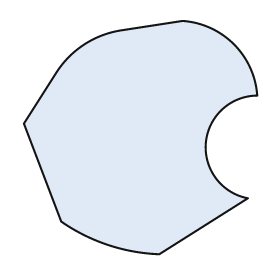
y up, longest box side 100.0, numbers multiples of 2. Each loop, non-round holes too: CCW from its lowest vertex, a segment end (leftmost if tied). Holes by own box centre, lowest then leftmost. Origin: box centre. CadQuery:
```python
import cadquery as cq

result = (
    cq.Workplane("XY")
    .moveTo(8.0, -50.0)
    .lineTo(46.0, -26.0)
    .threePointArc((28.0, -2.0), (50.0, 18.0))
    .threePointArc((40.0, 40.0), (18.0, 50.0))
    .lineTo(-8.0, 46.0)
    .threePointArc((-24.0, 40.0), (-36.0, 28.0))
    .lineTo(-50.0, 6.0)
    .lineTo(-34.0, -36.0)
    .threePointArc((-14.0, -46.0), (8.0, -50.0))
    .close()
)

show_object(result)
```